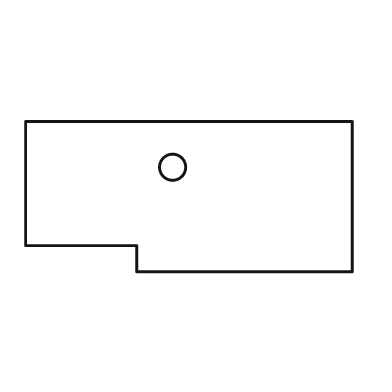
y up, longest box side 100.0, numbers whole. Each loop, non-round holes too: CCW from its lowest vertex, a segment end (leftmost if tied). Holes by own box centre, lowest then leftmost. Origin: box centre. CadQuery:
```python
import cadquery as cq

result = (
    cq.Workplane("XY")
    .moveTo(-16.0, -23.0)
    .lineTo(50.0, -23.0)
    .lineTo(50.0, 23.0)
    .lineTo(-50.0, 23.0)
    .lineTo(-50.0, -15.0)
    .lineTo(-16.0, -15.0)
    .close()
    .moveTo(-5.0, 9.0)
    .circle(4.0)
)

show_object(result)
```